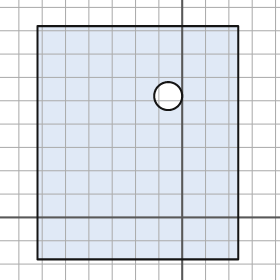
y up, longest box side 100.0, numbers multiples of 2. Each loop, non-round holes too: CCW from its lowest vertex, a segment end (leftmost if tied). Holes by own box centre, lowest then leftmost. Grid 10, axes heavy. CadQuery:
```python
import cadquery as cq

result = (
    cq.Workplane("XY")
    .moveTo(-62.0, -18.0)
    .lineTo(24.0, -18.0)
    .lineTo(24.0, 82.0)
    .lineTo(-62.0, 82.0)
    .close()
    .moveTo(-6.0, 52.0)
    .circle(6.0)
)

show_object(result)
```